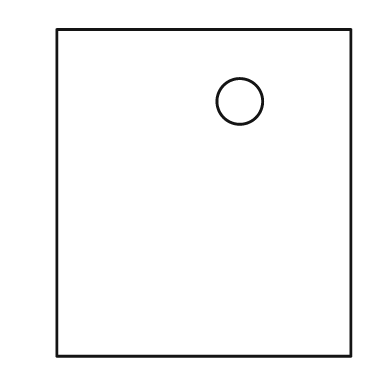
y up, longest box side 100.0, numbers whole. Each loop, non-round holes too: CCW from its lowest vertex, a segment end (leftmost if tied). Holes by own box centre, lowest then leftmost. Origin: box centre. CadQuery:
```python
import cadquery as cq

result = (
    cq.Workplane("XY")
    .moveTo(-45.0, -50.0)
    .lineTo(45.0, -50.0)
    .lineTo(45.0, 50.0)
    .lineTo(-45.0, 50.0)
    .close()
    .moveTo(11.0, 28.0)
    .circle(7.0)
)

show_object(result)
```